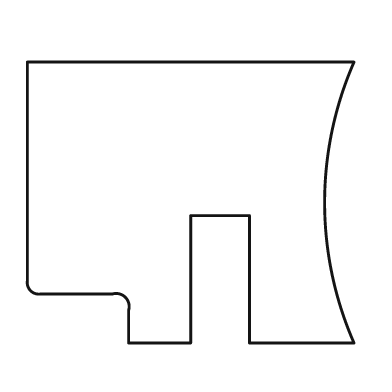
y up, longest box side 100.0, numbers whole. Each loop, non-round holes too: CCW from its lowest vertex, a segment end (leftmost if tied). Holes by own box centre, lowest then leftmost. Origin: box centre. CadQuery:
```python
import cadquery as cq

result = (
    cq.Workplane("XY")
    .moveTo(-19.0, -43.0)
    .lineTo(0.0, -43.0)
    .lineTo(0.0, -4.0)
    .lineTo(18.0, -4.0)
    .lineTo(18.0, -43.0)
    .lineTo(50.0, -43.0)
    .threePointArc((41.0, 0.0), (50.0, 43.0))
    .lineTo(-50.0, 43.0)
    .lineTo(-50.0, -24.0)
    .threePointArc((-49.0, -27.0), (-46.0, -28.0))
    .lineTo(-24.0, -28.0)
    .threePointArc((-20.0, -29.0), (-19.0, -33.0))
    .close()
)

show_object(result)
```